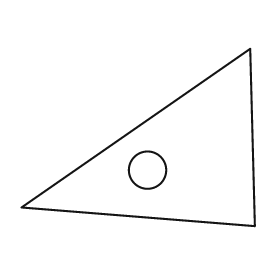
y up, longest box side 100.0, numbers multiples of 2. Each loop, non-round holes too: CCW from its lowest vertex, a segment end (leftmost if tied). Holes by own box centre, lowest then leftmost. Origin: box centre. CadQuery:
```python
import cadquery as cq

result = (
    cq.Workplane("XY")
    .moveTo(50.0, -38.0)
    .lineTo(48.0, 38.0)
    .lineTo(-50.0, -30.0)
    .close()
    .moveTo(4.0, -14.0)
    .circle(8.0)
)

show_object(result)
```